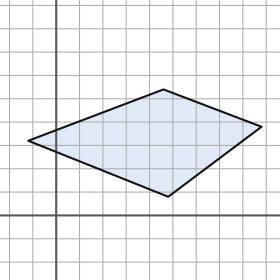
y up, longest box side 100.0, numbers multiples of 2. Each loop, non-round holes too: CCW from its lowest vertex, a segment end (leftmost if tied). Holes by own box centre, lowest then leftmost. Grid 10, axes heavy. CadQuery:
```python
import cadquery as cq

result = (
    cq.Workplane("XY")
    .moveTo(48.0, 8.0)
    .lineTo(88.0, 38.0)
    .lineTo(46.0, 54.0)
    .lineTo(-12.0, 32.0)
    .close()
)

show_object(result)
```